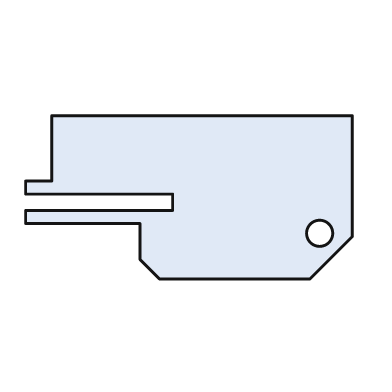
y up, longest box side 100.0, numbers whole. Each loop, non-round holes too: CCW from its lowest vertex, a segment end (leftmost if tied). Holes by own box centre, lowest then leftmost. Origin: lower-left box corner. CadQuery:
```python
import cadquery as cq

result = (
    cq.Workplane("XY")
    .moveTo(41.0, 0.0)
    .lineTo(87.0, 0.0)
    .lineTo(100.0, 13.0)
    .lineTo(100.0, 50.0)
    .lineTo(8.0, 50.0)
    .lineTo(8.0, 30.0)
    .lineTo(0.0, 30.0)
    .lineTo(0.0, 26.0)
    .lineTo(45.0, 26.0)
    .lineTo(45.0, 21.0)
    .lineTo(0.0, 21.0)
    .lineTo(0.0, 17.0)
    .lineTo(35.0, 17.0)
    .lineTo(35.0, 6.0)
    .close()
    .moveTo(90.0, 14.0)
    .circle(4.0)
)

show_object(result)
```